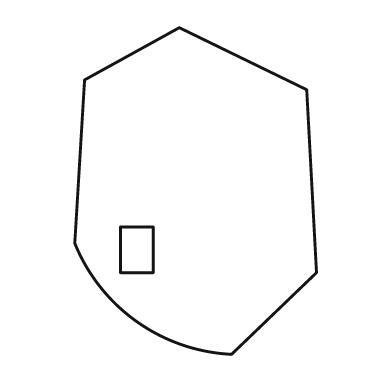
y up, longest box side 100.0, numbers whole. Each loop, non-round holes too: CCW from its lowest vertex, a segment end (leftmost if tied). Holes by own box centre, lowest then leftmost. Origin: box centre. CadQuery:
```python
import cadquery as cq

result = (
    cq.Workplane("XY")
    .moveTo(11.0, -50.0)
    .lineTo(37.0, -25.0)
    .lineTo(34.0, 31.0)
    .lineTo(-5.0, 50.0)
    .lineTo(-34.0, 34.0)
    .lineTo(-37.0, -16.0)
    .threePointArc((-18.0, -40.0), (11.0, -50.0))
    .close()
    .moveTo(-23.0, -25.0)
    .lineTo(-13.0, -25.0)
    .lineTo(-13.0, -11.0)
    .lineTo(-23.0, -11.0)
    .close()
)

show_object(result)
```